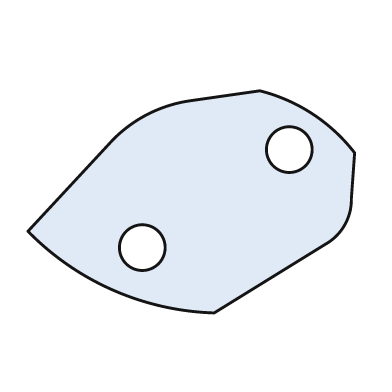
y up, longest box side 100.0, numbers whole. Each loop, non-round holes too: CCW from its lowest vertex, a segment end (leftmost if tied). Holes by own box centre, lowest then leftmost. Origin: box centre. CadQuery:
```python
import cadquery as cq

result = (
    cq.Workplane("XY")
    .moveTo(7.0, -34.0)
    .lineTo(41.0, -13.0)
    .threePointArc((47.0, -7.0), (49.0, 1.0))
    .lineTo(50.0, 15.0)
    .threePointArc((37.0, 27.0), (21.0, 34.0))
    .lineTo(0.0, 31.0)
    .threePointArc((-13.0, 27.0), (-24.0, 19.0))
    .lineTo(-50.0, -9.0)
    .threePointArc((-24.0, -27.0), (7.0, -34.0))
    .close()
    .moveTo(-15.0, -14.0)
    .circle(7.0)
    .moveTo(30.0, 16.0)
    .circle(7.0)
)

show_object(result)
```